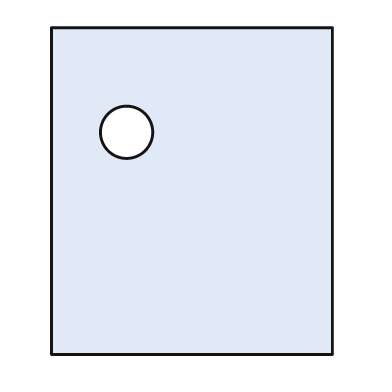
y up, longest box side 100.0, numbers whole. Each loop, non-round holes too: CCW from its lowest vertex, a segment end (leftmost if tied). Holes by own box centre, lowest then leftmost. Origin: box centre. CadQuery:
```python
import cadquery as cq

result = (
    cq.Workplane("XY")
    .moveTo(-43.0, -50.0)
    .lineTo(43.0, -50.0)
    .lineTo(43.0, 50.0)
    .lineTo(-43.0, 50.0)
    .close()
    .moveTo(-20.0, 18.0)
    .circle(8.0)
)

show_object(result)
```